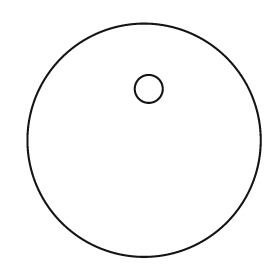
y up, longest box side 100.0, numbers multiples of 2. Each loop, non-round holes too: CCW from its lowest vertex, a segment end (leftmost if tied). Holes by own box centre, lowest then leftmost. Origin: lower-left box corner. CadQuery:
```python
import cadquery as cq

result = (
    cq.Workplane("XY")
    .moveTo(50.0, 50.0)
    .circle(50.0)
    .moveTo(52.0, 72.0)
    .circle(6.0)
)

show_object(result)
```